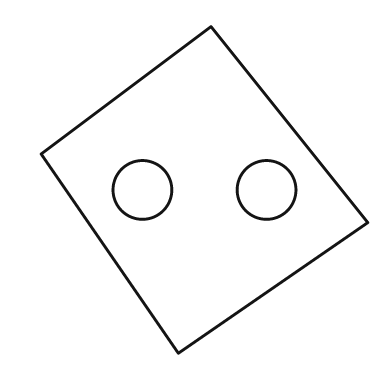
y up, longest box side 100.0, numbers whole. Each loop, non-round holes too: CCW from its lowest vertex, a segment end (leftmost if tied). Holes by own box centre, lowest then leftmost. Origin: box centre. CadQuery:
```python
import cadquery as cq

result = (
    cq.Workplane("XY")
    .moveTo(-8.0, -50.0)
    .lineTo(50.0, -10.0)
    .lineTo(2.0, 50.0)
    .lineTo(-50.0, 11.0)
    .close()
    .moveTo(-19.0, 0.0)
    .circle(9.0)
    .moveTo(19.0, 0.0)
    .circle(9.0)
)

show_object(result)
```